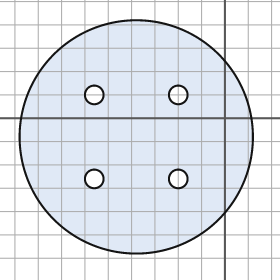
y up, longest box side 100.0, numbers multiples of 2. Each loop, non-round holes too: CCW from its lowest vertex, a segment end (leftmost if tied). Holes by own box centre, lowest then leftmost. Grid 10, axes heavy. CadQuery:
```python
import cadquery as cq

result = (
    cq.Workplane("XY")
    .moveTo(-38.0, -8.0)
    .circle(50.0)
    .moveTo(-56.0, -26.0)
    .circle(4.0)
    .moveTo(-20.0, -26.0)
    .circle(4.0)
    .moveTo(-56.0, 10.0)
    .circle(4.0)
    .moveTo(-20.0, 10.0)
    .circle(4.0)
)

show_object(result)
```